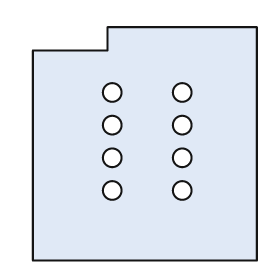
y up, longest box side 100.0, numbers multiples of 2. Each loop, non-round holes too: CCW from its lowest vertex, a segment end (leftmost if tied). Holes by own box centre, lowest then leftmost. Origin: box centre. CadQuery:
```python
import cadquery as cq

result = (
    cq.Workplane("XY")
    .moveTo(-48.0, -50.0)
    .lineTo(48.0, -50.0)
    .lineTo(48.0, 50.0)
    .lineTo(-16.0, 50.0)
    .lineTo(-16.0, 40.0)
    .lineTo(-48.0, 40.0)
    .close()
    .moveTo(-14.0, -20.0)
    .circle(4.0)
    .moveTo(16.0, -20.0)
    .circle(4.0)
    .moveTo(-14.0, -6.0)
    .circle(4.0)
    .moveTo(16.0, -6.0)
    .circle(4.0)
    .moveTo(-14.0, 8.0)
    .circle(4.0)
    .moveTo(16.0, 8.0)
    .circle(4.0)
    .moveTo(-14.0, 22.0)
    .circle(4.0)
    .moveTo(16.0, 22.0)
    .circle(4.0)
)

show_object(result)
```